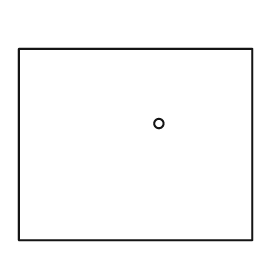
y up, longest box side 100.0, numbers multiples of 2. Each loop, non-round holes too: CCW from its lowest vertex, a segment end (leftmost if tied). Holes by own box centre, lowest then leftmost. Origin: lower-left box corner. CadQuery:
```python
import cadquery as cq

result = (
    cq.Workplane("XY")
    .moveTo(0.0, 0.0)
    .lineTo(100.0, 0.0)
    .lineTo(100.0, 82.0)
    .lineTo(0.0, 82.0)
    .close()
    .moveTo(60.0, 50.0)
    .circle(2.0)
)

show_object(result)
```